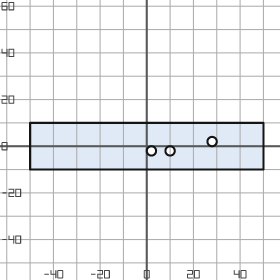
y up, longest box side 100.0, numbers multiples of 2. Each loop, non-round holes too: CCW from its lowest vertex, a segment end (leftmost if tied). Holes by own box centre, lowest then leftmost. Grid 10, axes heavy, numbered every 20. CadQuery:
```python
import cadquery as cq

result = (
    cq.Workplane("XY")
    .moveTo(-50.0, -10.0)
    .lineTo(50.0, -10.0)
    .lineTo(50.0, 10.0)
    .lineTo(-50.0, 10.0)
    .close()
    .moveTo(2.0, -2.0)
    .circle(2.0)
    .moveTo(10.0, -2.0)
    .circle(2.0)
    .moveTo(28.0, 2.0)
    .circle(2.0)
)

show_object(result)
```